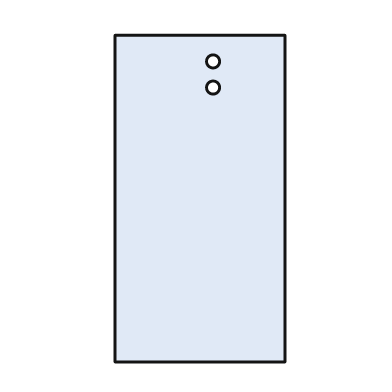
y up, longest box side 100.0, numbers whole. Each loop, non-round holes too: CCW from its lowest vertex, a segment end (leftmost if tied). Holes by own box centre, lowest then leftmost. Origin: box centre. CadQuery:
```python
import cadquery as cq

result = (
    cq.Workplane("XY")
    .moveTo(-26.0, -50.0)
    .lineTo(26.0, -50.0)
    .lineTo(26.0, 50.0)
    .lineTo(-26.0, 50.0)
    .close()
    .moveTo(4.0, 34.0)
    .circle(2.0)
    .moveTo(4.0, 42.0)
    .circle(2.0)
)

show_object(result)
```